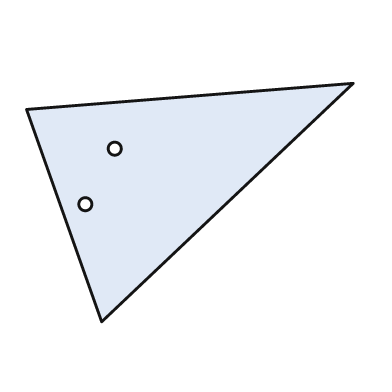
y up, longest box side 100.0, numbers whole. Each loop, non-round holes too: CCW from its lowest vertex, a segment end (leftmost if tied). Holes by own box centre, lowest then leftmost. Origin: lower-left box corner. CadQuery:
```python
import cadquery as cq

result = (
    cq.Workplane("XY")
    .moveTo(23.0, 0.0)
    .lineTo(100.0, 73.0)
    .lineTo(0.0, 65.0)
    .close()
    .moveTo(18.0, 36.0)
    .circle(2.0)
    .moveTo(27.0, 53.0)
    .circle(2.0)
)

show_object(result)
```